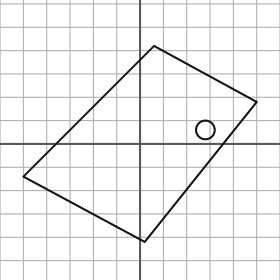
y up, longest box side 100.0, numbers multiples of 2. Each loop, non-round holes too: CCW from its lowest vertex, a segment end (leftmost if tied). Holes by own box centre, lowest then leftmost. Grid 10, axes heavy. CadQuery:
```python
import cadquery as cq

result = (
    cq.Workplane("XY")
    .moveTo(2.0, -42.0)
    .lineTo(50.0, 18.0)
    .lineTo(6.0, 42.0)
    .lineTo(-50.0, -14.0)
    .close()
    .moveTo(28.0, 6.0)
    .circle(4.0)
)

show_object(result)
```